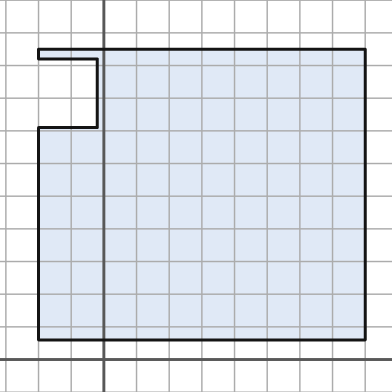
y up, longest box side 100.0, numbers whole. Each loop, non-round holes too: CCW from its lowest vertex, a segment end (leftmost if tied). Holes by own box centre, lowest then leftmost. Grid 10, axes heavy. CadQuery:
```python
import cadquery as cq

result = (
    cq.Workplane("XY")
    .moveTo(-20.0, 6.0)
    .lineTo(80.0, 6.0)
    .lineTo(80.0, 95.0)
    .lineTo(-20.0, 95.0)
    .lineTo(-20.0, 92.0)
    .lineTo(-2.0, 92.0)
    .lineTo(-2.0, 71.0)
    .lineTo(-20.0, 71.0)
    .close()
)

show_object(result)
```